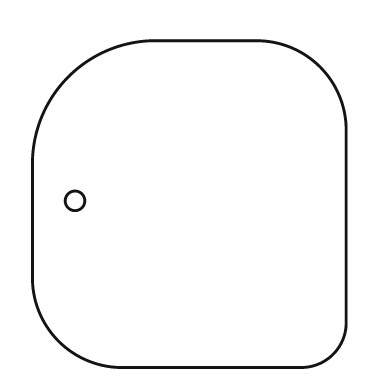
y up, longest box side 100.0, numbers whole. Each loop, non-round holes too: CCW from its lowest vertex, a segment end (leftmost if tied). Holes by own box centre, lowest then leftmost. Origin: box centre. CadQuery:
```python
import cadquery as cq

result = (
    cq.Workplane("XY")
    .moveTo(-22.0, -50.0)
    .lineTo(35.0, -50.0)
    .threePointArc((44.0, -46.0), (48.0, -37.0))
    .lineTo(48.0, 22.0)
    .threePointArc((40.0, 42.0), (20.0, 50.0))
    .lineTo(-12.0, 50.0)
    .threePointArc((-37.0, 39.0), (-48.0, 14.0))
    .lineTo(-48.0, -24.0)
    .threePointArc((-40.0, -42.0), (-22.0, -50.0))
    .close()
    .moveTo(-35.0, 1.0)
    .circle(3.0)
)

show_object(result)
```